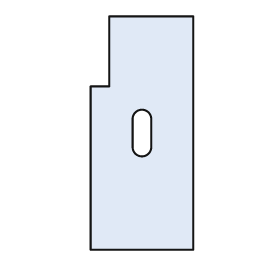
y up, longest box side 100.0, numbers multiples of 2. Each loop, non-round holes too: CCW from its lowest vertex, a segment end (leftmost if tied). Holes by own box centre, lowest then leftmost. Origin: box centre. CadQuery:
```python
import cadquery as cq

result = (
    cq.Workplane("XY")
    .moveTo(-22.0, -50.0)
    .lineTo(22.0, -50.0)
    .lineTo(22.0, 50.0)
    .lineTo(-14.0, 50.0)
    .lineTo(-14.0, 20.0)
    .lineTo(-22.0, 20.0)
    .close()
    .moveTo(-4.0, -6.0)
    .threePointArc((0.0, -10.0), (4.0, -6.0))
    .lineTo(4.0, 6.0)
    .threePointArc((0.0, 10.0), (-4.0, 6.0))
    .close()
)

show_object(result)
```